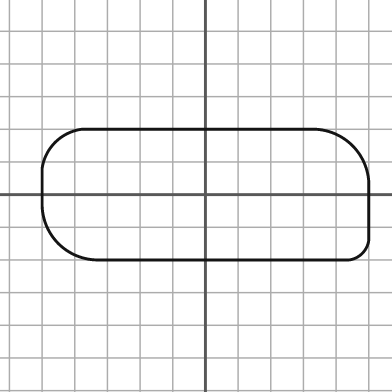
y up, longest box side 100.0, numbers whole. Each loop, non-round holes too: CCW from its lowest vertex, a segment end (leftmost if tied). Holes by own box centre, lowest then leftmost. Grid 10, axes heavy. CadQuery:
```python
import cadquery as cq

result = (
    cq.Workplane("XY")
    .moveTo(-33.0, -20.0)
    .lineTo(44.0, -20.0)
    .threePointArc((48.0, -18.0), (50.0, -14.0))
    .lineTo(50.0, 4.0)
    .threePointArc((45.0, 15.0), (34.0, 20.0))
    .lineTo(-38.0, 20.0)
    .threePointArc((-46.0, 16.0), (-50.0, 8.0))
    .lineTo(-50.0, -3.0)
    .threePointArc((-45.0, -15.0), (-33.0, -20.0))
    .close()
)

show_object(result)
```